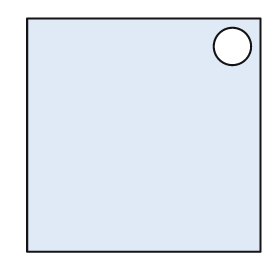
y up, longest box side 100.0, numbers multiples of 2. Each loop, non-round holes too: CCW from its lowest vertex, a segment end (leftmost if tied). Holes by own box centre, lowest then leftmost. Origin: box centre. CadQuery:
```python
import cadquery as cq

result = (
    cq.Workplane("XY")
    .moveTo(-50.0, -50.0)
    .lineTo(50.0, -50.0)
    .lineTo(50.0, 50.0)
    .lineTo(-50.0, 50.0)
    .close()
    .moveTo(38.0, 38.0)
    .circle(8.0)
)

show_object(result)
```